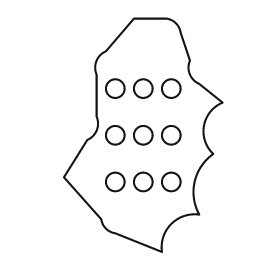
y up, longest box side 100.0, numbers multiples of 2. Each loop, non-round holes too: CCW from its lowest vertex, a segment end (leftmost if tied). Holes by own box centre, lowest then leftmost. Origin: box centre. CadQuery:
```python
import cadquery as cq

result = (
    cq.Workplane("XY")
    .moveTo(8.0, -50.0)
    .threePointArc((12.0, -38.0), (24.0, -34.0))
    .threePointArc((22.0, -20.0), (30.0, -8.0))
    .threePointArc((26.0, 4.0), (34.0, 14.0))
    .lineTo(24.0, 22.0)
    .threePointArc((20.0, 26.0), (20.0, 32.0))
    .lineTo(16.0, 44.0)
    .threePointArc((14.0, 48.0), (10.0, 50.0))
    .lineTo(-4.0, 50.0)
    .lineTo(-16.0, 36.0)
    .threePointArc((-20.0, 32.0), (-20.0, 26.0))
    .lineTo(-20.0, 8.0)
    .threePointArc((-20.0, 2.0), (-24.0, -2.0))
    .lineTo(-34.0, -18.0)
    .lineTo(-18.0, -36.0)
    .threePointArc((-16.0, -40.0), (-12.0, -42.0))
    .close()
    .moveTo(-12.0, -20.0)
    .circle(4.0)
    .moveTo(0.0, -20.0)
    .circle(4.0)
    .moveTo(12.0, -20.0)
    .circle(4.0)
    .moveTo(-12.0, 0.0)
    .circle(4.0)
    .moveTo(0.0, 0.0)
    .circle(4.0)
    .moveTo(12.0, 0.0)
    .circle(4.0)
    .moveTo(-12.0, 20.0)
    .circle(4.0)
    .moveTo(0.0, 20.0)
    .circle(4.0)
    .moveTo(12.0, 20.0)
    .circle(4.0)
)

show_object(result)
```